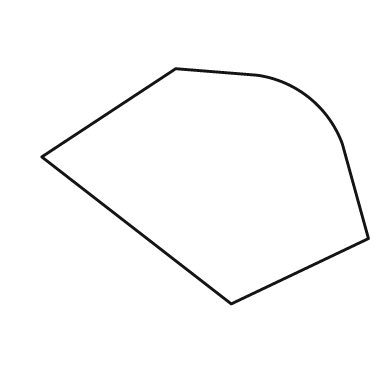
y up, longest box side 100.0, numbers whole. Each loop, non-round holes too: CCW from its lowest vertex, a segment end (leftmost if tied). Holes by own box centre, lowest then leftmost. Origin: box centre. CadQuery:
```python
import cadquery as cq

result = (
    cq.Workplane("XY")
    .moveTo(8.0, -36.0)
    .lineTo(50.0, -16.0)
    .lineTo(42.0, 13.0)
    .threePointArc((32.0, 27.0), (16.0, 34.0))
    .lineTo(-9.0, 36.0)
    .lineTo(-50.0, 9.0)
    .close()
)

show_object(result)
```